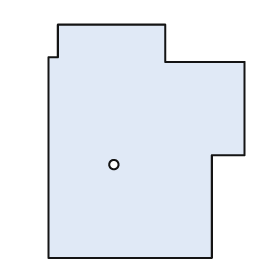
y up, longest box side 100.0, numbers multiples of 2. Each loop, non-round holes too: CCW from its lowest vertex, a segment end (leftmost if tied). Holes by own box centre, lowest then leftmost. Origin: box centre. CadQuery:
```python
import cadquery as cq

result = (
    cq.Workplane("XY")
    .moveTo(-42.0, -50.0)
    .lineTo(28.0, -50.0)
    .lineTo(28.0, -6.0)
    .lineTo(42.0, -6.0)
    .lineTo(42.0, 34.0)
    .lineTo(8.0, 34.0)
    .lineTo(8.0, 50.0)
    .lineTo(-38.0, 50.0)
    .lineTo(-38.0, 36.0)
    .lineTo(-42.0, 36.0)
    .close()
    .moveTo(-14.0, -10.0)
    .circle(2.0)
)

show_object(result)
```